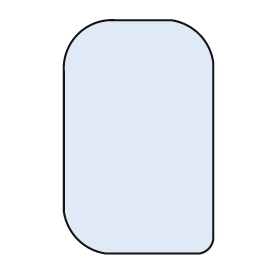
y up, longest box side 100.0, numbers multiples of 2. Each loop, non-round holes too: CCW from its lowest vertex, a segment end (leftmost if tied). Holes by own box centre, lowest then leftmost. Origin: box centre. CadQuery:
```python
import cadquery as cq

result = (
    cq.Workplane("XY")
    .moveTo(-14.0, -50.0)
    .lineTo(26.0, -50.0)
    .threePointArc((30.0, -48.0), (32.0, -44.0))
    .lineTo(32.0, 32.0)
    .threePointArc((26.0, 44.0), (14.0, 50.0))
    .lineTo(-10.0, 50.0)
    .threePointArc((-26.0, 44.0), (-32.0, 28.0))
    .lineTo(-32.0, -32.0)
    .threePointArc((-26.0, -44.0), (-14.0, -50.0))
    .close()
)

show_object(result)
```